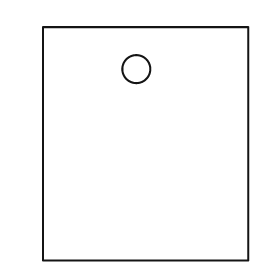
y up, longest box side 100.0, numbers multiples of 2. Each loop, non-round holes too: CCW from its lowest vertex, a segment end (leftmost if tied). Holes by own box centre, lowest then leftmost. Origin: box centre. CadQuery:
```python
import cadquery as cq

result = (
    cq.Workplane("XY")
    .moveTo(-44.0, -50.0)
    .lineTo(44.0, -50.0)
    .lineTo(44.0, 50.0)
    .lineTo(-44.0, 50.0)
    .close()
    .moveTo(-4.0, 32.0)
    .circle(6.0)
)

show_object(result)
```